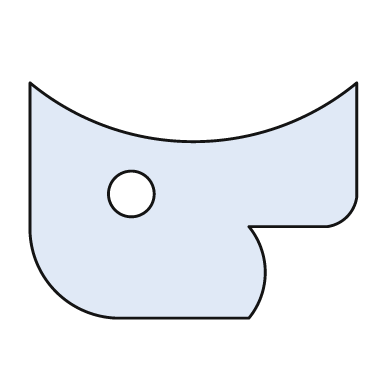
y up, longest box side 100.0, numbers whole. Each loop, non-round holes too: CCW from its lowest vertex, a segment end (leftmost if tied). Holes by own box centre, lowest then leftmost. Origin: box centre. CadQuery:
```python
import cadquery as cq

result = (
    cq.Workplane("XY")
    .moveTo(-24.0, -36.0)
    .lineTo(17.0, -36.0)
    .threePointArc((22.0, -22.0), (17.0, -8.0))
    .lineTo(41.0, -8.0)
    .threePointArc((47.0, -5.0), (50.0, 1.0))
    .lineTo(50.0, 36.0)
    .threePointArc((0.0, 18.0), (-50.0, 36.0))
    .lineTo(-50.0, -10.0)
    .threePointArc((-42.0, -28.0), (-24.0, -36.0))
    .close()
    .moveTo(-19.0, 2.0)
    .circle(7.0)
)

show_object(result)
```